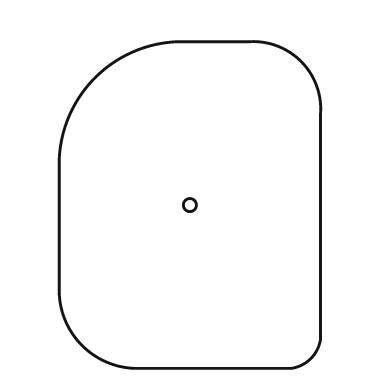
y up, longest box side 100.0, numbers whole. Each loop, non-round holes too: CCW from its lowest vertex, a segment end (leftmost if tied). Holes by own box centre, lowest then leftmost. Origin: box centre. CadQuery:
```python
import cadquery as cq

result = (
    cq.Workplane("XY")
    .moveTo(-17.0, -50.0)
    .lineTo(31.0, -50.0)
    .threePointArc((37.0, -47.0), (40.0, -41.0))
    .lineTo(40.0, 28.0)
    .threePointArc((34.0, 44.0), (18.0, 50.0))
    .lineTo(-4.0, 50.0)
    .threePointArc((-29.0, 39.0), (-40.0, 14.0))
    .lineTo(-40.0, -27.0)
    .threePointArc((-33.0, -43.0), (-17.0, -50.0))
    .close()
    .moveTo(0.0, 0.0)
    .circle(2.0)
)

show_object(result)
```